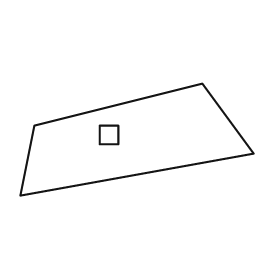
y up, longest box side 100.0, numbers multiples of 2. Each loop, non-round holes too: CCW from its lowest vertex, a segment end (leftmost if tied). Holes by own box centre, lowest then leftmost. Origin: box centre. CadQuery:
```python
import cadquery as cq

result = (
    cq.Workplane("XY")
    .moveTo(-50.0, -24.0)
    .lineTo(50.0, -6.0)
    .lineTo(28.0, 24.0)
    .lineTo(-44.0, 6.0)
    .close()
    .moveTo(-16.0, -2.0)
    .lineTo(-8.0, -2.0)
    .lineTo(-8.0, 6.0)
    .lineTo(-16.0, 6.0)
    .close()
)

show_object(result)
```